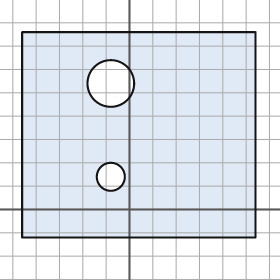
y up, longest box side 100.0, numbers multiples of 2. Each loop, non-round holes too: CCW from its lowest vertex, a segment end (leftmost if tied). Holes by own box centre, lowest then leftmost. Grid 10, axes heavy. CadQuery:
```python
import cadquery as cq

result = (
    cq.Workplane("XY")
    .moveTo(-46.0, -12.0)
    .lineTo(54.0, -12.0)
    .lineTo(54.0, 76.0)
    .lineTo(-46.0, 76.0)
    .close()
    .moveTo(-8.0, 14.0)
    .circle(6.0)
    .moveTo(-8.0, 54.0)
    .circle(10.0)
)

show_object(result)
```